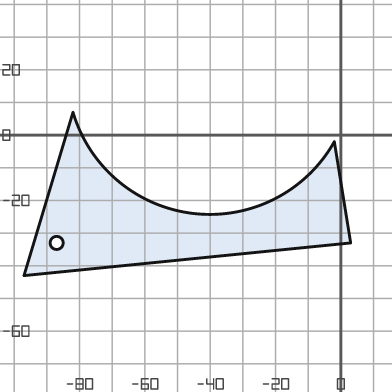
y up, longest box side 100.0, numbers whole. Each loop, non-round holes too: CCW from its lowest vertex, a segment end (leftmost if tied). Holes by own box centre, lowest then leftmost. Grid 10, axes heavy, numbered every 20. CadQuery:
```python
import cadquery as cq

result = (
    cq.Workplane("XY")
    .moveTo(-97.0, -43.0)
    .lineTo(3.0, -33.0)
    .lineTo(-2.0, -2.0)
    .threePointArc((-45.0, -24.0), (-82.0, 7.0))
    .close()
    .moveTo(-87.0, -33.0)
    .circle(2.0)
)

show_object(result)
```